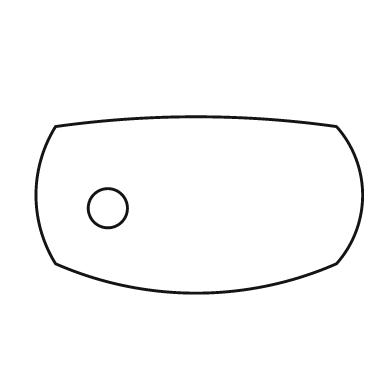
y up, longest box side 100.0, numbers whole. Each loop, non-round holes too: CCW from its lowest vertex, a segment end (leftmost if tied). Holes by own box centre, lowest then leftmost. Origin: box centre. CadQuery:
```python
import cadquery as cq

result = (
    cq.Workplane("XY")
    .moveTo(-44.0, -18.0)
    .threePointArc((-1.0, -27.0), (42.0, -18.0))
    .threePointArc((50.0, 3.0), (42.0, 24.0))
    .threePointArc((-1.0, 27.0), (-44.0, 24.0))
    .threePointArc((-50.0, 3.0), (-44.0, -18.0))
    .close()
    .moveTo(-28.0, -1.0)
    .circle(6.0)
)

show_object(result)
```